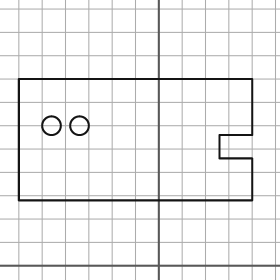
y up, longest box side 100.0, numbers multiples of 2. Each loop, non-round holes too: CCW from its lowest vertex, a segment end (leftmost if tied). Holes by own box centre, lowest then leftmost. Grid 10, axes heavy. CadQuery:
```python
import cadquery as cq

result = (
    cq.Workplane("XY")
    .moveTo(-60.0, 28.0)
    .lineTo(40.0, 28.0)
    .lineTo(40.0, 46.0)
    .lineTo(26.0, 46.0)
    .lineTo(26.0, 56.0)
    .lineTo(40.0, 56.0)
    .lineTo(40.0, 80.0)
    .lineTo(-60.0, 80.0)
    .close()
    .moveTo(-46.0, 60.0)
    .circle(4.0)
    .moveTo(-34.0, 60.0)
    .circle(4.0)
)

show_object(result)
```